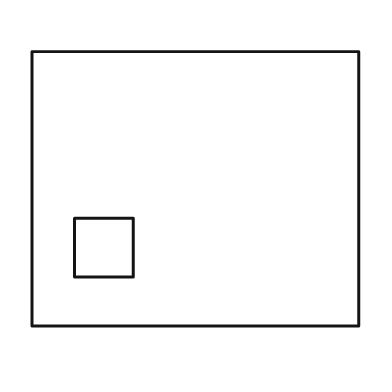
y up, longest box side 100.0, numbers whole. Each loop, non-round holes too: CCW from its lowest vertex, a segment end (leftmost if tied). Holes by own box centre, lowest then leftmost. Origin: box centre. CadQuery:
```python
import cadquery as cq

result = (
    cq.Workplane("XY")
    .moveTo(-50.0, -42.0)
    .lineTo(50.0, -42.0)
    .lineTo(50.0, 42.0)
    .lineTo(-50.0, 42.0)
    .close()
    .moveTo(-37.0, -27.0)
    .lineTo(-19.0, -27.0)
    .lineTo(-19.0, -9.0)
    .lineTo(-37.0, -9.0)
    .close()
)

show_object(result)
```